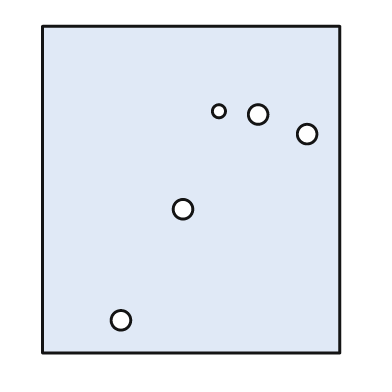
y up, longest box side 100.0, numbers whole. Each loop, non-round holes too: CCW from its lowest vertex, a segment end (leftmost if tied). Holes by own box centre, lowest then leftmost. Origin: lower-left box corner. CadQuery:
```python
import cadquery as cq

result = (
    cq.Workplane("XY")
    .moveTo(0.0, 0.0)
    .lineTo(91.0, 0.0)
    .lineTo(91.0, 100.0)
    .lineTo(0.0, 100.0)
    .close()
    .moveTo(24.0, 10.0)
    .circle(3.0)
    .moveTo(43.0, 44.0)
    .circle(3.0)
    .moveTo(81.0, 67.0)
    .circle(3.0)
    .moveTo(66.0, 73.0)
    .circle(3.0)
    .moveTo(54.0, 74.0)
    .circle(2.0)
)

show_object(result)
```